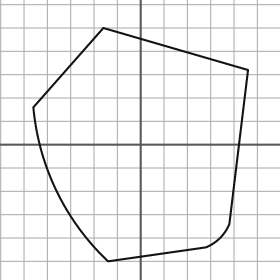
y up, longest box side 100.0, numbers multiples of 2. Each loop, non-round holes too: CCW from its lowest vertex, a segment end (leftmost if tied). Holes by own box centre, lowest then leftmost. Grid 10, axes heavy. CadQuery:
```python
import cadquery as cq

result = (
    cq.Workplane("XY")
    .moveTo(-14.0, -50.0)
    .lineTo(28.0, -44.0)
    .threePointArc((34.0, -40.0), (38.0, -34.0))
    .lineTo(46.0, 32.0)
    .lineTo(-16.0, 50.0)
    .lineTo(-46.0, 16.0)
    .threePointArc((-36.0, -20.0), (-14.0, -50.0))
    .close()
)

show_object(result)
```